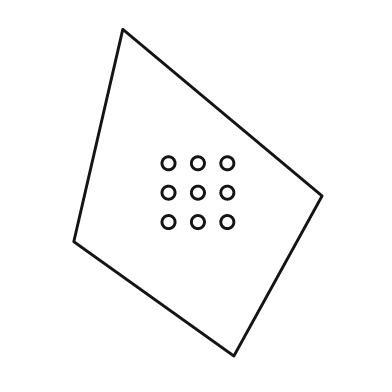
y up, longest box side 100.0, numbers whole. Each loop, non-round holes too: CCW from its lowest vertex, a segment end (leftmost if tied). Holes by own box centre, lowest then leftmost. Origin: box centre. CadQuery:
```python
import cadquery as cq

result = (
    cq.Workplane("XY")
    .moveTo(11.0, -50.0)
    .lineTo(38.0, -1.0)
    .lineTo(-23.0, 50.0)
    .lineTo(-38.0, -15.0)
    .close()
    .moveTo(-9.0, -9.0)
    .circle(2.0)
    .moveTo(0.0, -9.0)
    .circle(2.0)
    .moveTo(9.0, -9.0)
    .circle(2.0)
    .moveTo(-9.0, 0.0)
    .circle(2.0)
    .moveTo(0.0, 0.0)
    .circle(2.0)
    .moveTo(9.0, 0.0)
    .circle(2.0)
    .moveTo(-9.0, 9.0)
    .circle(2.0)
    .moveTo(0.0, 9.0)
    .circle(2.0)
    .moveTo(9.0, 9.0)
    .circle(2.0)
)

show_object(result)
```